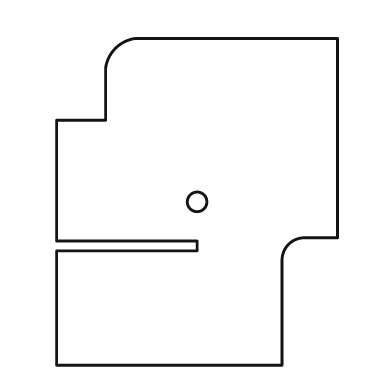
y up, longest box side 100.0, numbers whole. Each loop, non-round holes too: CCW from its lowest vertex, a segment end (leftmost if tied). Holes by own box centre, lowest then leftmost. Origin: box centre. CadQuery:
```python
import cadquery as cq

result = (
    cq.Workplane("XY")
    .moveTo(-43.0, -50.0)
    .lineTo(26.0, -50.0)
    .lineTo(26.0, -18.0)
    .threePointArc((28.0, -13.0), (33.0, -11.0))
    .lineTo(43.0, -11.0)
    .lineTo(43.0, 50.0)
    .lineTo(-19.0, 50.0)
    .threePointArc((-25.0, 47.0), (-28.0, 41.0))
    .lineTo(-28.0, 25.0)
    .lineTo(-43.0, 25.0)
    .lineTo(-43.0, -12.0)
    .lineTo(0.0, -12.0)
    .lineTo(0.0, -15.0)
    .lineTo(-43.0, -15.0)
    .close()
    .moveTo(0.0, 0.0)
    .circle(3.0)
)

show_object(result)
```